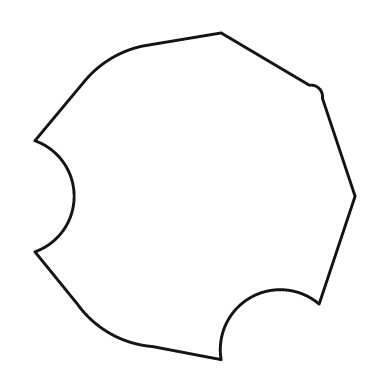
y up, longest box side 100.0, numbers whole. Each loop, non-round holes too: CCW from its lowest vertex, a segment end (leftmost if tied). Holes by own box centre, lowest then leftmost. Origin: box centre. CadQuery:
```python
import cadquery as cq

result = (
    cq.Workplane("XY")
    .moveTo(8.0, -50.0)
    .threePointArc((17.0, -31.0), (38.0, -33.0))
    .lineTo(49.0, 0.0)
    .lineTo(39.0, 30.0)
    .threePointArc((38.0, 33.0), (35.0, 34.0))
    .lineTo(8.0, 50.0)
    .lineTo(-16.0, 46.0)
    .threePointArc((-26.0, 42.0), (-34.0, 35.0))
    .lineTo(-49.0, 17.0)
    .threePointArc((-37.0, 0.0), (-49.0, -17.0))
    .lineTo(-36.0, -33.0)
    .threePointArc((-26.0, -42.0), (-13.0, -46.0))
    .close()
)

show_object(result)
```